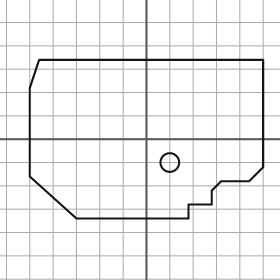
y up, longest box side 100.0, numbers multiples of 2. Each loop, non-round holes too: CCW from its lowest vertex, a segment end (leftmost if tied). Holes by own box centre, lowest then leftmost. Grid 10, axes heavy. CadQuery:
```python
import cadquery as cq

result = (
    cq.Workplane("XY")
    .moveTo(-30.0, -34.0)
    .lineTo(18.0, -34.0)
    .lineTo(18.0, -28.0)
    .lineTo(28.0, -28.0)
    .lineTo(28.0, -22.0)
    .lineTo(32.0, -18.0)
    .lineTo(44.0, -18.0)
    .lineTo(50.0, -12.0)
    .lineTo(50.0, 34.0)
    .lineTo(-46.0, 34.0)
    .lineTo(-50.0, 22.0)
    .lineTo(-50.0, -16.0)
    .close()
    .moveTo(10.0, -10.0)
    .circle(4.0)
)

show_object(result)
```